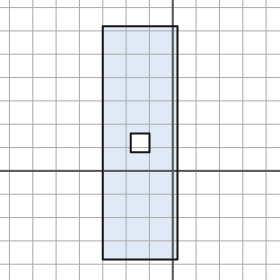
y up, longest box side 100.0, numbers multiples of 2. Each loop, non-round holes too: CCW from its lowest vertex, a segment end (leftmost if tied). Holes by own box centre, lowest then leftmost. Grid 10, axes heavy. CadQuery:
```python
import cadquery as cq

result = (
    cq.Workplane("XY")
    .moveTo(-30.0, -38.0)
    .lineTo(2.0, -38.0)
    .lineTo(2.0, 62.0)
    .lineTo(-30.0, 62.0)
    .close()
    .moveTo(-18.0, 8.0)
    .lineTo(-10.0, 8.0)
    .lineTo(-10.0, 16.0)
    .lineTo(-18.0, 16.0)
    .close()
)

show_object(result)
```